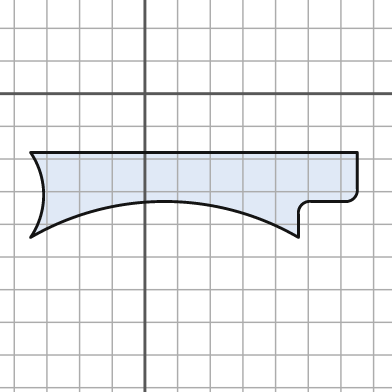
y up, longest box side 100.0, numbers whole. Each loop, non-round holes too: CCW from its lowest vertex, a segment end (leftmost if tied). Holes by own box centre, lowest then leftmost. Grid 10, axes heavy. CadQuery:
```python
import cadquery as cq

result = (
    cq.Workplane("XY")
    .moveTo(-35.0, -44.0)
    .threePointArc((6.0, -33.0), (47.0, -44.0))
    .lineTo(47.0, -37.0)
    .threePointArc((48.0, -34.0), (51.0, -33.0))
    .lineTo(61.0, -33.0)
    .threePointArc((64.0, -32.0), (65.0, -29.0))
    .lineTo(65.0, -18.0)
    .lineTo(-35.0, -18.0)
    .threePointArc((-31.0, -31.0), (-35.0, -44.0))
    .close()
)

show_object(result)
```